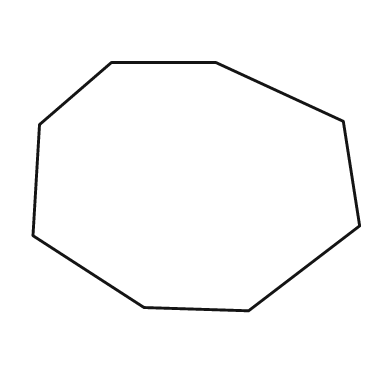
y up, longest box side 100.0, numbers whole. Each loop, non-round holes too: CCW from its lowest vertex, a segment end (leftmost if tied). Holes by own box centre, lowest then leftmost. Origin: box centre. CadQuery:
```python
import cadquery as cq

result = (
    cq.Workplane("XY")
    .moveTo(16.0, -38.0)
    .lineTo(50.0, -12.0)
    .lineTo(45.0, 20.0)
    .lineTo(6.0, 38.0)
    .lineTo(-26.0, 38.0)
    .lineTo(-48.0, 19.0)
    .lineTo(-50.0, -15.0)
    .lineTo(-16.0, -37.0)
    .close()
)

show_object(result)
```